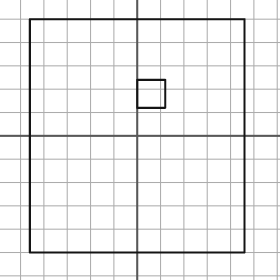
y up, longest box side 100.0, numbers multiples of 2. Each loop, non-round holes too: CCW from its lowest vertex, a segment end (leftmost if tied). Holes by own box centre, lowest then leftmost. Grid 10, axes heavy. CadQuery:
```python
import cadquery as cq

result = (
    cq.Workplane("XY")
    .moveTo(-46.0, -50.0)
    .lineTo(46.0, -50.0)
    .lineTo(46.0, 50.0)
    .lineTo(-46.0, 50.0)
    .close()
    .moveTo(0.0, 12.0)
    .lineTo(12.0, 12.0)
    .lineTo(12.0, 24.0)
    .lineTo(0.0, 24.0)
    .close()
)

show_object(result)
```